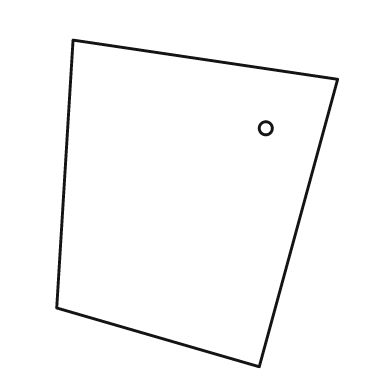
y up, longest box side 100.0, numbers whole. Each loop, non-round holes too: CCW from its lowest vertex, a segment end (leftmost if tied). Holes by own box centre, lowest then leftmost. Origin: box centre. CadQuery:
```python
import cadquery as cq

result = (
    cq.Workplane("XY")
    .moveTo(19.0, -50.0)
    .lineTo(43.0, 38.0)
    .lineTo(-38.0, 50.0)
    .lineTo(-43.0, -32.0)
    .close()
    .moveTo(21.0, 23.0)
    .circle(2.0)
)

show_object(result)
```